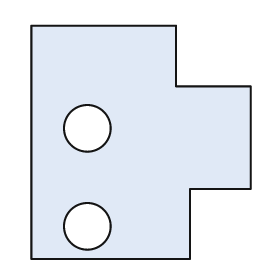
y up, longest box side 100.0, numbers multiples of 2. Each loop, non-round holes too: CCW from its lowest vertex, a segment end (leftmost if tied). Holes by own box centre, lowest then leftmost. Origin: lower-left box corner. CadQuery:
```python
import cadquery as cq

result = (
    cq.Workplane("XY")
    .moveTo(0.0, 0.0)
    .lineTo(68.0, 0.0)
    .lineTo(68.0, 30.0)
    .lineTo(94.0, 30.0)
    .lineTo(94.0, 74.0)
    .lineTo(62.0, 74.0)
    .lineTo(62.0, 100.0)
    .lineTo(0.0, 100.0)
    .close()
    .moveTo(24.0, 14.0)
    .circle(10.0)
    .moveTo(24.0, 56.0)
    .circle(10.0)
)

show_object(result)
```